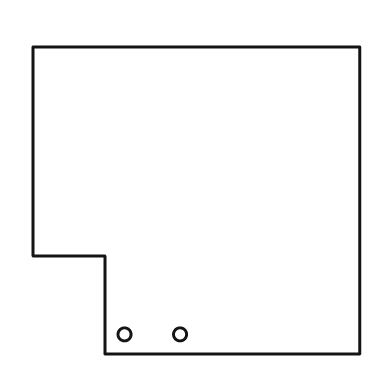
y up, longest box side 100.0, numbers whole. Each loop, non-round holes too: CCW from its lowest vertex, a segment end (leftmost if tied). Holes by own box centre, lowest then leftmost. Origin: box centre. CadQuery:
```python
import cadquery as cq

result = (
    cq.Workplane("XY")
    .moveTo(-28.0, -47.0)
    .lineTo(50.0, -47.0)
    .lineTo(50.0, 47.0)
    .lineTo(-50.0, 47.0)
    .lineTo(-50.0, -17.0)
    .lineTo(-28.0, -17.0)
    .close()
    .moveTo(-22.0, -41.0)
    .circle(2.0)
    .moveTo(-5.0, -41.0)
    .circle(2.0)
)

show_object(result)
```